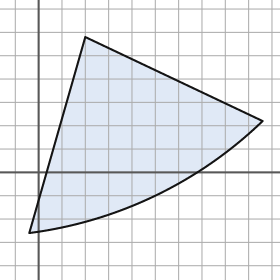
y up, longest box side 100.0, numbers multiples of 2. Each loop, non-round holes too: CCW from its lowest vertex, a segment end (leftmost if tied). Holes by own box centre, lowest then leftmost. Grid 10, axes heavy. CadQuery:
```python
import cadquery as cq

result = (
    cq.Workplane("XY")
    .moveTo(-4.0, -26.0)
    .threePointArc((50.0, -10.0), (96.0, 22.0))
    .lineTo(20.0, 58.0)
    .close()
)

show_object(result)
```